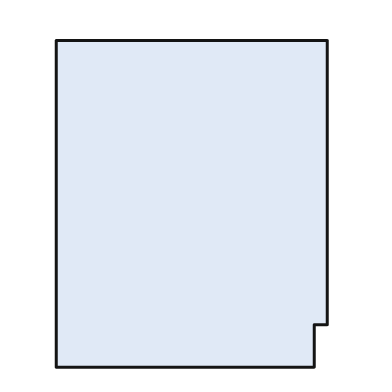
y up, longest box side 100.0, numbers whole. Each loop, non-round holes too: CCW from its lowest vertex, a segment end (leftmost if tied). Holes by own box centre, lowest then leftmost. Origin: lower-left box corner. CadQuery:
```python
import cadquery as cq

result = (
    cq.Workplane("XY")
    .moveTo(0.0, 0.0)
    .lineTo(79.0, 0.0)
    .lineTo(79.0, 13.0)
    .lineTo(83.0, 13.0)
    .lineTo(83.0, 100.0)
    .lineTo(0.0, 100.0)
    .close()
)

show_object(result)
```